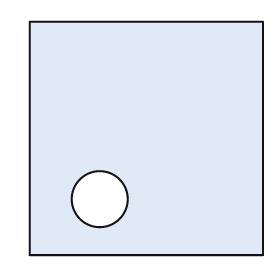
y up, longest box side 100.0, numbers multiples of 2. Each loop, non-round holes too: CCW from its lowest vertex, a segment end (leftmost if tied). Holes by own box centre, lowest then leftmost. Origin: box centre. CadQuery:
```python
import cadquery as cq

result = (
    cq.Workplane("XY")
    .moveTo(-50.0, -50.0)
    .lineTo(50.0, -50.0)
    .lineTo(50.0, 50.0)
    .lineTo(-50.0, 50.0)
    .close()
    .moveTo(-20.0, -26.0)
    .circle(12.0)
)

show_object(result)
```